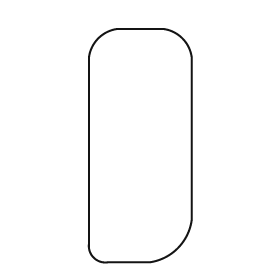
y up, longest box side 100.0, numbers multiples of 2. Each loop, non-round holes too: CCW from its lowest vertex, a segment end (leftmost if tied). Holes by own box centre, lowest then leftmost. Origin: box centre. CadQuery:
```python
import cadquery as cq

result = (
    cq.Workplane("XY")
    .moveTo(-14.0, -50.0)
    .lineTo(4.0, -50.0)
    .threePointArc((16.0, -44.0), (22.0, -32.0))
    .lineTo(22.0, 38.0)
    .threePointArc((18.0, 46.0), (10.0, 50.0))
    .lineTo(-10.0, 50.0)
    .threePointArc((-18.0, 46.0), (-22.0, 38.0))
    .lineTo(-22.0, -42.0)
    .threePointArc((-20.0, -48.0), (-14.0, -50.0))
    .close()
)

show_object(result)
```